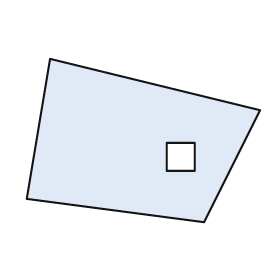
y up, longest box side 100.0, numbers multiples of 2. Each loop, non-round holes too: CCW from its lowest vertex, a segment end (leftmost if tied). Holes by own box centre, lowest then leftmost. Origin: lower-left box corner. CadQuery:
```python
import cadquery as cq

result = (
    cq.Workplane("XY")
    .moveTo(76.0, 0.0)
    .lineTo(100.0, 48.0)
    .lineTo(10.0, 70.0)
    .lineTo(0.0, 10.0)
    .close()
    .moveTo(60.0, 22.0)
    .lineTo(72.0, 22.0)
    .lineTo(72.0, 34.0)
    .lineTo(60.0, 34.0)
    .close()
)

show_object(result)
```